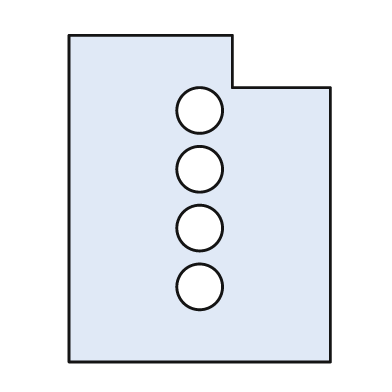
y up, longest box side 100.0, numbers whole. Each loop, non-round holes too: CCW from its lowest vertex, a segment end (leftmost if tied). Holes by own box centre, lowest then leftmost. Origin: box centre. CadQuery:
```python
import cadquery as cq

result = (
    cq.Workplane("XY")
    .moveTo(-40.0, -50.0)
    .lineTo(40.0, -50.0)
    .lineTo(40.0, 34.0)
    .lineTo(10.0, 34.0)
    .lineTo(10.0, 50.0)
    .lineTo(-40.0, 50.0)
    .close()
    .moveTo(0.0, -27.0)
    .circle(7.0)
    .moveTo(0.0, -9.0)
    .circle(7.0)
    .moveTo(0.0, 9.0)
    .circle(7.0)
    .moveTo(0.0, 27.0)
    .circle(7.0)
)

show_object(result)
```